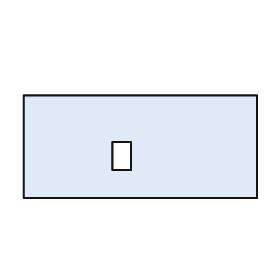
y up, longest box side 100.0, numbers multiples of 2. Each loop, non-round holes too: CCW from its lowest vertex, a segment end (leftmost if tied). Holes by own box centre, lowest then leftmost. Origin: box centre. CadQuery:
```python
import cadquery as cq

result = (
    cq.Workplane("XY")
    .moveTo(-50.0, -22.0)
    .lineTo(50.0, -22.0)
    .lineTo(50.0, 22.0)
    .lineTo(-50.0, 22.0)
    .close()
    .moveTo(-12.0, -10.0)
    .lineTo(-4.0, -10.0)
    .lineTo(-4.0, 2.0)
    .lineTo(-12.0, 2.0)
    .close()
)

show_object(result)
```